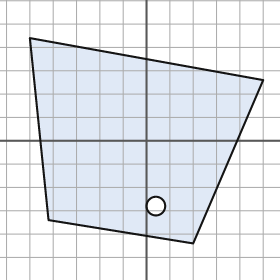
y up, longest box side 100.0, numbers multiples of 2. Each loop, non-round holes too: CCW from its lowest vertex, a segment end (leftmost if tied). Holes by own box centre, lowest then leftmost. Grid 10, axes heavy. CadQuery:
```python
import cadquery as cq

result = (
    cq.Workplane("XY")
    .moveTo(20.0, -44.0)
    .lineTo(50.0, 26.0)
    .lineTo(-50.0, 44.0)
    .lineTo(-42.0, -34.0)
    .close()
    .moveTo(4.0, -28.0)
    .circle(4.0)
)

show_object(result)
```